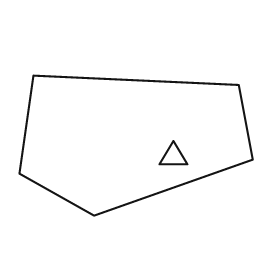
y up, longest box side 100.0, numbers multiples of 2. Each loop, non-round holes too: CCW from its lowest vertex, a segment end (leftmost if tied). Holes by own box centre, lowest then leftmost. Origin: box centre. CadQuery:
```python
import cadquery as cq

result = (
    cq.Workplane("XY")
    .moveTo(-18.0, -30.0)
    .lineTo(50.0, -6.0)
    .lineTo(44.0, 26.0)
    .lineTo(-44.0, 30.0)
    .lineTo(-50.0, -12.0)
    .close()
    .moveTo(10.0, -8.0)
    .lineTo(22.0, -8.0)
    .lineTo(16.0, 2.0)
    .close()
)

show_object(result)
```